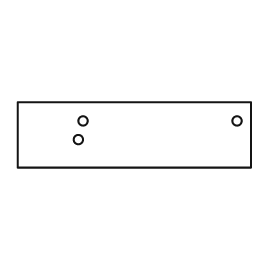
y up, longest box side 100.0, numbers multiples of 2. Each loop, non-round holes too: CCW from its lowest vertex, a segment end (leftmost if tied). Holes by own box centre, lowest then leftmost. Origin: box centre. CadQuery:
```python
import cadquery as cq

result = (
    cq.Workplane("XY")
    .moveTo(-50.0, -14.0)
    .lineTo(50.0, -14.0)
    .lineTo(50.0, 14.0)
    .lineTo(-50.0, 14.0)
    .close()
    .moveTo(-24.0, -2.0)
    .circle(2.0)
    .moveTo(-22.0, 6.0)
    .circle(2.0)
    .moveTo(44.0, 6.0)
    .circle(2.0)
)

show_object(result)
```